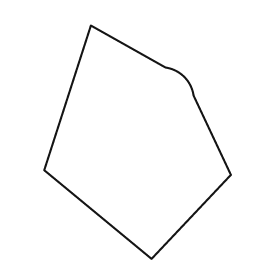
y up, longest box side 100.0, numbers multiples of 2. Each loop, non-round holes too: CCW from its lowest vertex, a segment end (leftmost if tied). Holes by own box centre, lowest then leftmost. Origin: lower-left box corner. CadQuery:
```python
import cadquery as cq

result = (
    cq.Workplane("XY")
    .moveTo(46.0, 0.0)
    .lineTo(80.0, 36.0)
    .lineTo(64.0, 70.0)
    .threePointArc((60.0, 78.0), (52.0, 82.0))
    .lineTo(20.0, 100.0)
    .lineTo(0.0, 38.0)
    .close()
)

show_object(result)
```